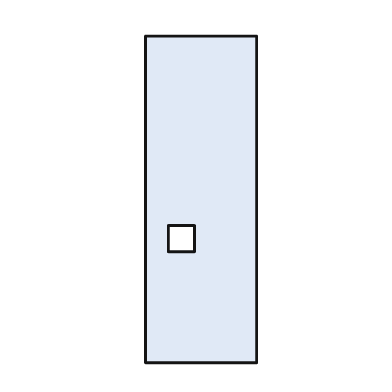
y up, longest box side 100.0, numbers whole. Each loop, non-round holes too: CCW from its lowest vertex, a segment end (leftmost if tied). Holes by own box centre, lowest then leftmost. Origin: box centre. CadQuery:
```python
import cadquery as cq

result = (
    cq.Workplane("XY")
    .moveTo(-17.0, -50.0)
    .lineTo(17.0, -50.0)
    .lineTo(17.0, 50.0)
    .lineTo(-17.0, 50.0)
    .close()
    .moveTo(-10.0, -16.0)
    .lineTo(-2.0, -16.0)
    .lineTo(-2.0, -8.0)
    .lineTo(-10.0, -8.0)
    .close()
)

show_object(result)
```